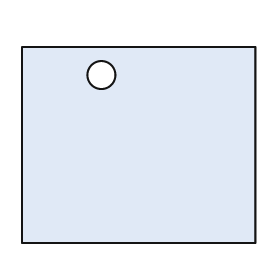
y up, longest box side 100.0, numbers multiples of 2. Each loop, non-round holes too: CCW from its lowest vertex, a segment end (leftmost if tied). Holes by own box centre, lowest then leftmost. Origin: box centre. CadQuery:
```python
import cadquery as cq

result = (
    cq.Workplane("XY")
    .moveTo(-50.0, -42.0)
    .lineTo(50.0, -42.0)
    .lineTo(50.0, 42.0)
    .lineTo(-50.0, 42.0)
    .close()
    .moveTo(-16.0, 30.0)
    .circle(6.0)
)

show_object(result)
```